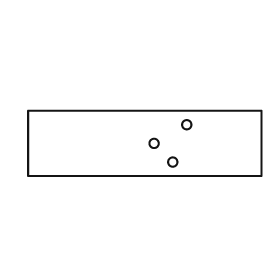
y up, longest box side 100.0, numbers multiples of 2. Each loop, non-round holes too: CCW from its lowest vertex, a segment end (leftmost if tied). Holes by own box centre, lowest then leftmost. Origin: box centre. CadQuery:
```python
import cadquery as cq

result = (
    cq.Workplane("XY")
    .moveTo(-50.0, -14.0)
    .lineTo(50.0, -14.0)
    .lineTo(50.0, 14.0)
    .lineTo(-50.0, 14.0)
    .close()
    .moveTo(12.0, -8.0)
    .circle(2.0)
    .moveTo(4.0, 0.0)
    .circle(2.0)
    .moveTo(18.0, 8.0)
    .circle(2.0)
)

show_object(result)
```